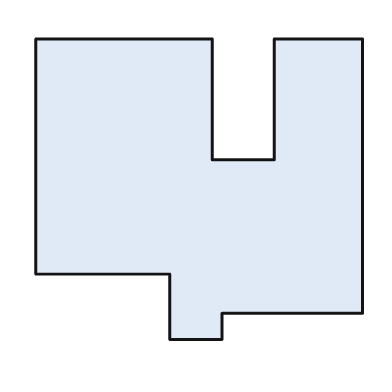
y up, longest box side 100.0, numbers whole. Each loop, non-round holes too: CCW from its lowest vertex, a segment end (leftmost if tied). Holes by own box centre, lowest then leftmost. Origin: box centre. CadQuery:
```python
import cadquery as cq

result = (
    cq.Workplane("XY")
    .moveTo(-9.0, -46.0)
    .lineTo(7.0, -46.0)
    .lineTo(7.0, -38.0)
    .lineTo(50.0, -38.0)
    .lineTo(50.0, 46.0)
    .lineTo(23.0, 46.0)
    .lineTo(23.0, 9.0)
    .lineTo(4.0, 9.0)
    .lineTo(4.0, 46.0)
    .lineTo(-50.0, 46.0)
    .lineTo(-50.0, -26.0)
    .lineTo(-9.0, -26.0)
    .close()
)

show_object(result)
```